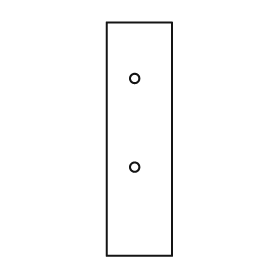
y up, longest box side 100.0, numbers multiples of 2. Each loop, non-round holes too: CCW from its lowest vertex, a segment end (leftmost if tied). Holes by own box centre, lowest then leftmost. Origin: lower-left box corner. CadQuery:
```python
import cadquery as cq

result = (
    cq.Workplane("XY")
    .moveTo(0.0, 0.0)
    .lineTo(28.0, 0.0)
    .lineTo(28.0, 100.0)
    .lineTo(0.0, 100.0)
    .close()
    .moveTo(12.0, 38.0)
    .circle(2.0)
    .moveTo(12.0, 76.0)
    .circle(2.0)
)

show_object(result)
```